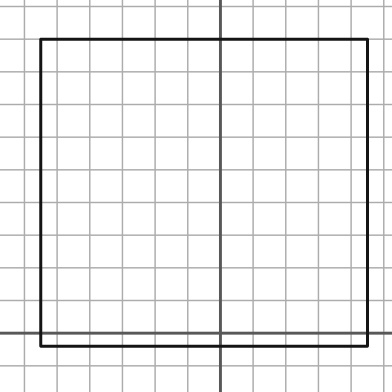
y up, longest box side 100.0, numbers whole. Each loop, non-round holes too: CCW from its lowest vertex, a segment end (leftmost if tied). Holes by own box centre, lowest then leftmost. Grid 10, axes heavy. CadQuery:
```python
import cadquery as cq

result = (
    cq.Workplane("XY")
    .moveTo(-55.0, -4.0)
    .lineTo(45.0, -4.0)
    .lineTo(45.0, 90.0)
    .lineTo(-55.0, 90.0)
    .close()
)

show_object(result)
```